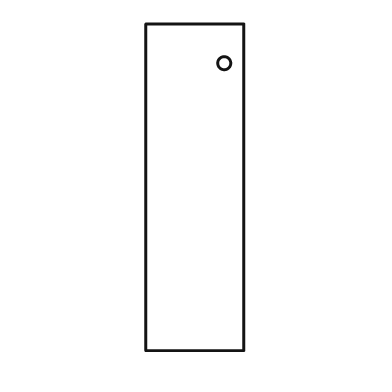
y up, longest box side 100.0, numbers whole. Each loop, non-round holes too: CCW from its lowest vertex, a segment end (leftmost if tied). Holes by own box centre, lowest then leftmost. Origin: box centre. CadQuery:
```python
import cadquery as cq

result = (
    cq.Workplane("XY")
    .moveTo(-15.0, -50.0)
    .lineTo(15.0, -50.0)
    .lineTo(15.0, 50.0)
    .lineTo(-15.0, 50.0)
    .close()
    .moveTo(9.0, 38.0)
    .circle(2.0)
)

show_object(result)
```